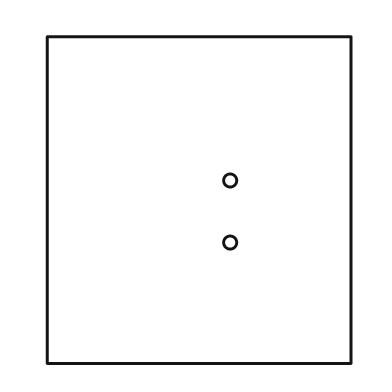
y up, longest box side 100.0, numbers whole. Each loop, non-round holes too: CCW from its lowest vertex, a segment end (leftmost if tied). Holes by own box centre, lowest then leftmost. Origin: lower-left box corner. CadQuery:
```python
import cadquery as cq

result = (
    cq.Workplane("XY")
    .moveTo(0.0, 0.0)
    .lineTo(93.0, 0.0)
    .lineTo(93.0, 100.0)
    .lineTo(0.0, 100.0)
    .close()
    .moveTo(56.0, 37.0)
    .circle(2.0)
    .moveTo(56.0, 56.0)
    .circle(2.0)
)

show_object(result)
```